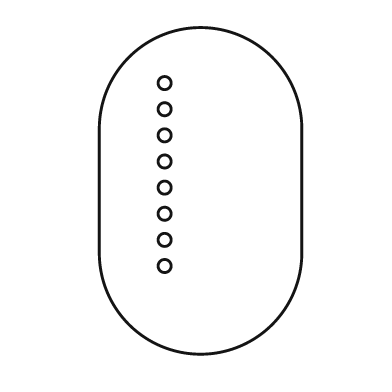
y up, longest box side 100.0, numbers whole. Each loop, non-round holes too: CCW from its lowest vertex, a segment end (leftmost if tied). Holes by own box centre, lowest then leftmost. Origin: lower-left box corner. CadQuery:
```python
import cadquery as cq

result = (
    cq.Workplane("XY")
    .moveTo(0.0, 31.0)
    .threePointArc((31.0, 0.0), (62.0, 31.0))
    .lineTo(62.0, 69.0)
    .threePointArc((31.0, 100.0), (0.0, 69.0))
    .close()
    .moveTo(20.0, 27.0)
    .circle(2.0)
    .moveTo(20.0, 35.0)
    .circle(2.0)
    .moveTo(20.0, 43.0)
    .circle(2.0)
    .moveTo(20.0, 51.0)
    .circle(2.0)
    .moveTo(20.0, 59.0)
    .circle(2.0)
    .moveTo(20.0, 67.0)
    .circle(2.0)
    .moveTo(20.0, 75.0)
    .circle(2.0)
    .moveTo(20.0, 83.0)
    .circle(2.0)
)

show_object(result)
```